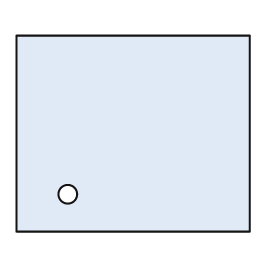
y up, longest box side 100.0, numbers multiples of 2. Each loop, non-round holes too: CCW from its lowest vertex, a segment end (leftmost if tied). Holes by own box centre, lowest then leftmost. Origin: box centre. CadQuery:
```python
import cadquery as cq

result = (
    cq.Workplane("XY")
    .moveTo(-50.0, -42.0)
    .lineTo(50.0, -42.0)
    .lineTo(50.0, 42.0)
    .lineTo(-50.0, 42.0)
    .close()
    .moveTo(-28.0, -26.0)
    .circle(4.0)
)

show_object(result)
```